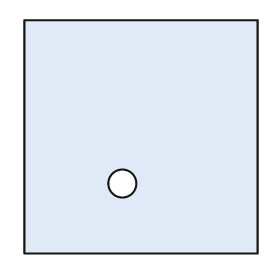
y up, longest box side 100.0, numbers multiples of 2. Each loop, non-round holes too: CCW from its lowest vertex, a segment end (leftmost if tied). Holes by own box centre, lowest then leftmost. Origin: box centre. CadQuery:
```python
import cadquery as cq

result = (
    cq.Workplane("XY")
    .moveTo(-50.0, -50.0)
    .lineTo(50.0, -50.0)
    .lineTo(50.0, 50.0)
    .lineTo(-50.0, 50.0)
    .close()
    .moveTo(-8.0, -20.0)
    .circle(6.0)
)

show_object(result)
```